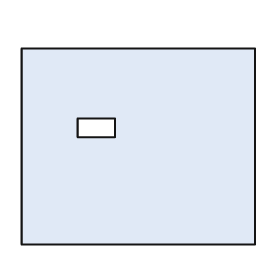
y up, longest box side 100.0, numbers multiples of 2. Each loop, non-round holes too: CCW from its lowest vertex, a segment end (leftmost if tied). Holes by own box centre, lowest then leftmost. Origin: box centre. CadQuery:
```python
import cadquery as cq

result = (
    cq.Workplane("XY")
    .moveTo(-50.0, -42.0)
    .lineTo(50.0, -42.0)
    .lineTo(50.0, 42.0)
    .lineTo(-50.0, 42.0)
    .close()
    .moveTo(-26.0, 4.0)
    .lineTo(-10.0, 4.0)
    .lineTo(-10.0, 12.0)
    .lineTo(-26.0, 12.0)
    .close()
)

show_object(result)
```